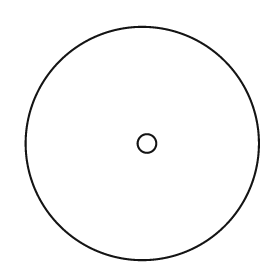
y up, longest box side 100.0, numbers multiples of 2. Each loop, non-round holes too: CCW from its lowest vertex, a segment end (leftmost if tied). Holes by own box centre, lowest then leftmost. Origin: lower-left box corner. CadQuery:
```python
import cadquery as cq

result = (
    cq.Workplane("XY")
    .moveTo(50.0, 50.0)
    .circle(50.0)
    .moveTo(52.0, 50.0)
    .circle(4.0)
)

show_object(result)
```